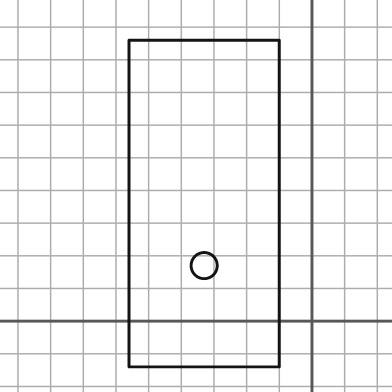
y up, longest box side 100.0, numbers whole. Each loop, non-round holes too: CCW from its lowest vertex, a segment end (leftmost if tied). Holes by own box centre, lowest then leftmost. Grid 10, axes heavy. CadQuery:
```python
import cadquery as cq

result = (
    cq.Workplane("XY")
    .moveTo(-56.0, -14.0)
    .lineTo(-10.0, -14.0)
    .lineTo(-10.0, 86.0)
    .lineTo(-56.0, 86.0)
    .close()
    .moveTo(-33.0, 17.0)
    .circle(4.0)
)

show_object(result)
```